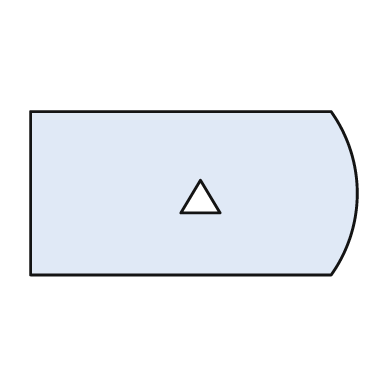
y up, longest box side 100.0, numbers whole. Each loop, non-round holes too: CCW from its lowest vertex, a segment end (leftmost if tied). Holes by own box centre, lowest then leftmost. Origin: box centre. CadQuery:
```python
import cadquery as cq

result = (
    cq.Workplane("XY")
    .moveTo(-50.0, -25.0)
    .lineTo(42.0, -25.0)
    .threePointArc((50.0, 0.0), (42.0, 25.0))
    .lineTo(-50.0, 25.0)
    .close()
    .moveTo(-4.0, -6.0)
    .lineTo(8.0, -6.0)
    .lineTo(2.0, 4.0)
    .close()
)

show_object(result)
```